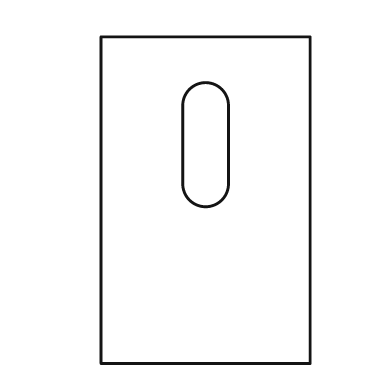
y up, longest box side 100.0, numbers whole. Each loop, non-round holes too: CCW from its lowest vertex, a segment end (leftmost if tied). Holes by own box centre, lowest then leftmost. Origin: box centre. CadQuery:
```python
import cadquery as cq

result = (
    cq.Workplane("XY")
    .moveTo(-32.0, -50.0)
    .lineTo(32.0, -50.0)
    .lineTo(32.0, 50.0)
    .lineTo(-32.0, 50.0)
    .close()
    .moveTo(-7.0, 5.0)
    .threePointArc((0.0, -2.0), (7.0, 5.0))
    .lineTo(7.0, 29.0)
    .threePointArc((0.0, 36.0), (-7.0, 29.0))
    .close()
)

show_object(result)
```